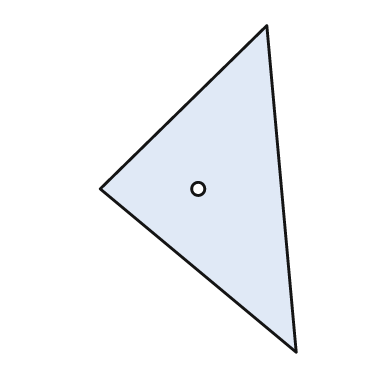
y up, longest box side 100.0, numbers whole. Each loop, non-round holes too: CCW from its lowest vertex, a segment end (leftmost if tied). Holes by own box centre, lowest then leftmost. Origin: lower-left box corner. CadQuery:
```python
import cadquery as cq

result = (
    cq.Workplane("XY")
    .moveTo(60.0, 0.0)
    .lineTo(51.0, 100.0)
    .lineTo(0.0, 50.0)
    .close()
    .moveTo(30.0, 50.0)
    .circle(2.0)
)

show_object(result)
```